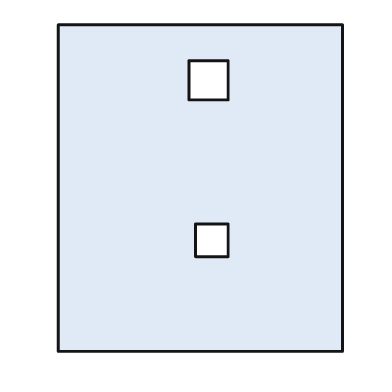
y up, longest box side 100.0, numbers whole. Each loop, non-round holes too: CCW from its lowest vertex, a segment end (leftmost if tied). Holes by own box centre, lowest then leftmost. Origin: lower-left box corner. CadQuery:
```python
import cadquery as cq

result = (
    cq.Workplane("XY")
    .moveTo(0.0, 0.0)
    .lineTo(87.0, 0.0)
    .lineTo(87.0, 100.0)
    .lineTo(0.0, 100.0)
    .close()
    .moveTo(42.0, 29.0)
    .lineTo(52.0, 29.0)
    .lineTo(52.0, 39.0)
    .lineTo(42.0, 39.0)
    .close()
    .moveTo(40.0, 77.0)
    .lineTo(52.0, 77.0)
    .lineTo(52.0, 89.0)
    .lineTo(40.0, 89.0)
    .close()
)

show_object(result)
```